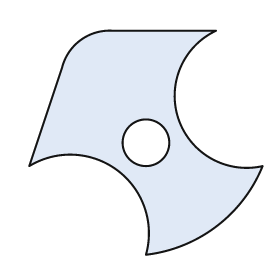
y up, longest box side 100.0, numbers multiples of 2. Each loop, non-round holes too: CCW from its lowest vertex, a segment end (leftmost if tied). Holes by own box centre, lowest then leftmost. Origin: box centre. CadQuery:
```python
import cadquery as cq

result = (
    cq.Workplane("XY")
    .moveTo(0.0, -48.0)
    .threePointArc((30.0, -36.0), (50.0, -10.0))
    .threePointArc((14.0, 10.0), (30.0, 48.0))
    .lineTo(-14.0, 48.0)
    .threePointArc((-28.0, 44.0), (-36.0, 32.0))
    .lineTo(-50.0, -10.0)
    .threePointArc((-12.0, -12.0), (0.0, -48.0))
    .close()
    .moveTo(0.0, 0.0)
    .circle(10.0)
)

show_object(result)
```